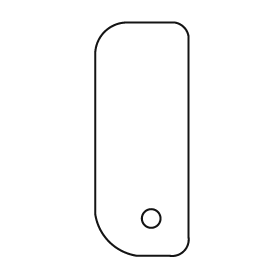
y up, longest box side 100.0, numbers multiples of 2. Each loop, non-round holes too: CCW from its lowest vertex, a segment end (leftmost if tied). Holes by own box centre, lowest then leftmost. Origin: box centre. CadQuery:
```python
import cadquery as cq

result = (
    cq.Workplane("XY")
    .moveTo(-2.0, -50.0)
    .lineTo(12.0, -50.0)
    .threePointArc((18.0, -48.0), (20.0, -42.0))
    .lineTo(20.0, 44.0)
    .threePointArc((18.0, 48.0), (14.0, 50.0))
    .lineTo(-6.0, 50.0)
    .threePointArc((-16.0, 46.0), (-20.0, 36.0))
    .lineTo(-20.0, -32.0)
    .threePointArc((-14.0, -44.0), (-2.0, -50.0))
    .close()
    .moveTo(4.0, -34.0)
    .circle(4.0)
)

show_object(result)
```